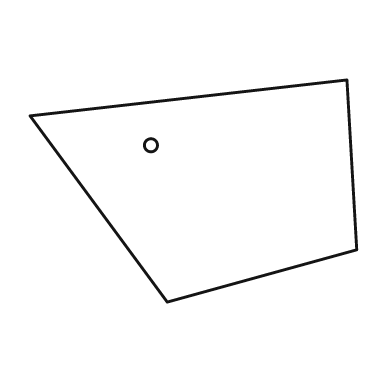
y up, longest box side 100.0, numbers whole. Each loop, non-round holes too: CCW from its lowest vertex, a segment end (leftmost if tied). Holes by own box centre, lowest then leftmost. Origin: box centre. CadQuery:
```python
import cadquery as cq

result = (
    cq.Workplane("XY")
    .moveTo(-8.0, -34.0)
    .lineTo(50.0, -18.0)
    .lineTo(47.0, 34.0)
    .lineTo(-50.0, 23.0)
    .close()
    .moveTo(-13.0, 14.0)
    .circle(2.0)
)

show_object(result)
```